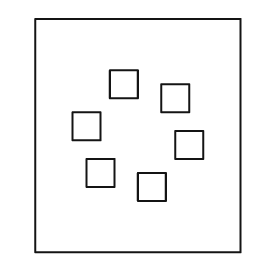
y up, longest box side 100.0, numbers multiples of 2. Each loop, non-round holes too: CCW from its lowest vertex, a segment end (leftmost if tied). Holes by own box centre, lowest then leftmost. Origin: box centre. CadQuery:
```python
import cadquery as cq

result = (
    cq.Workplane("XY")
    .moveTo(-44.0, -50.0)
    .lineTo(44.0, -50.0)
    .lineTo(44.0, 50.0)
    .lineTo(-44.0, 50.0)
    .close()
    .moveTo(0.0, -28.0)
    .lineTo(12.0, -28.0)
    .lineTo(12.0, -16.0)
    .lineTo(0.0, -16.0)
    .close()
    .moveTo(-22.0, -22.0)
    .lineTo(-10.0, -22.0)
    .lineTo(-10.0, -10.0)
    .lineTo(-22.0, -10.0)
    .close()
    .moveTo(16.0, -10.0)
    .lineTo(28.0, -10.0)
    .lineTo(28.0, 2.0)
    .lineTo(16.0, 2.0)
    .close()
    .moveTo(-28.0, -2.0)
    .lineTo(-16.0, -2.0)
    .lineTo(-16.0, 10.0)
    .lineTo(-28.0, 10.0)
    .close()
    .moveTo(10.0, 10.0)
    .lineTo(22.0, 10.0)
    .lineTo(22.0, 22.0)
    .lineTo(10.0, 22.0)
    .close()
    .moveTo(-12.0, 16.0)
    .lineTo(0.0, 16.0)
    .lineTo(0.0, 28.0)
    .lineTo(-12.0, 28.0)
    .close()
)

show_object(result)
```